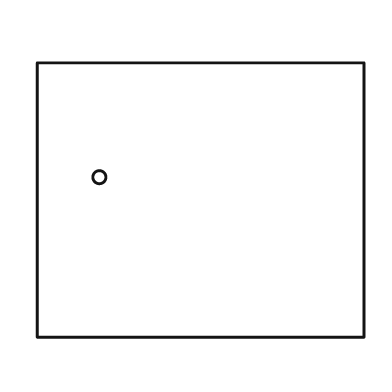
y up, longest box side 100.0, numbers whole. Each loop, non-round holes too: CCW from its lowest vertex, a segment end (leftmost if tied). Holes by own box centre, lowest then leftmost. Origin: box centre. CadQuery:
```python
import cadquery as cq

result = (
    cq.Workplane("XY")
    .moveTo(-50.0, -42.0)
    .lineTo(50.0, -42.0)
    .lineTo(50.0, 42.0)
    .lineTo(-50.0, 42.0)
    .close()
    .moveTo(-31.0, 7.0)
    .circle(2.0)
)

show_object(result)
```